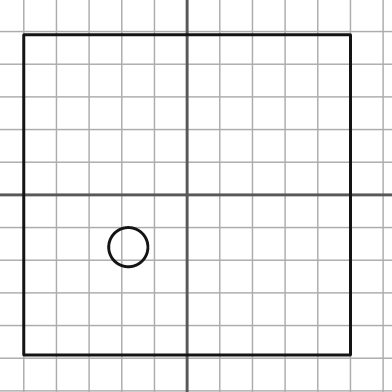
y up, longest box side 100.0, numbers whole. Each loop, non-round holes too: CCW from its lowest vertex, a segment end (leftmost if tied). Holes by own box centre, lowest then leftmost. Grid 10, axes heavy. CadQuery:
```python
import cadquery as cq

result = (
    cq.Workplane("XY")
    .moveTo(-50.0, -49.0)
    .lineTo(50.0, -49.0)
    .lineTo(50.0, 49.0)
    .lineTo(-50.0, 49.0)
    .close()
    .moveTo(-18.0, -16.0)
    .circle(6.0)
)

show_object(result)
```